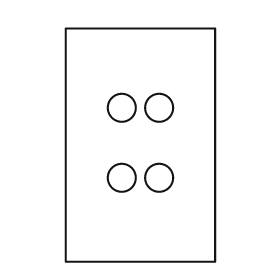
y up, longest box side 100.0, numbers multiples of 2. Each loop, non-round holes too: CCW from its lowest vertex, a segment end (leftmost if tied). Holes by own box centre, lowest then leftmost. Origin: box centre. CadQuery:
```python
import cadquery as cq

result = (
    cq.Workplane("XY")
    .moveTo(-32.0, -50.0)
    .lineTo(32.0, -50.0)
    .lineTo(32.0, 50.0)
    .lineTo(-32.0, 50.0)
    .close()
    .moveTo(-8.0, -14.0)
    .circle(6.0)
    .moveTo(8.0, -14.0)
    .circle(6.0)
    .moveTo(-8.0, 16.0)
    .circle(6.0)
    .moveTo(8.0, 16.0)
    .circle(6.0)
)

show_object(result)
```